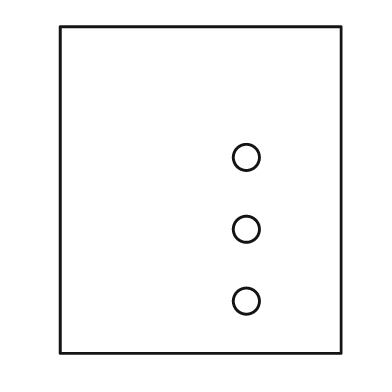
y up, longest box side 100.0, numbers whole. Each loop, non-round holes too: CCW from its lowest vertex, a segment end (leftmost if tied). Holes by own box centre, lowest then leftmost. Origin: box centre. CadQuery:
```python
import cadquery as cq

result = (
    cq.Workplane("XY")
    .moveTo(-43.0, -50.0)
    .lineTo(43.0, -50.0)
    .lineTo(43.0, 50.0)
    .lineTo(-43.0, 50.0)
    .close()
    .moveTo(14.0, -34.0)
    .circle(4.0)
    .moveTo(14.0, -12.0)
    .circle(4.0)
    .moveTo(14.0, 10.0)
    .circle(4.0)
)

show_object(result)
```